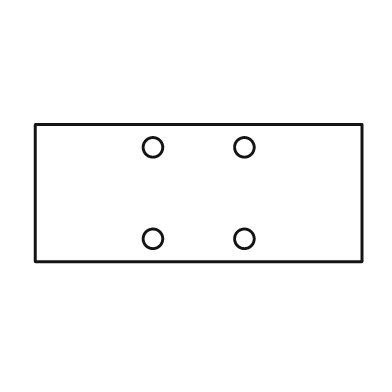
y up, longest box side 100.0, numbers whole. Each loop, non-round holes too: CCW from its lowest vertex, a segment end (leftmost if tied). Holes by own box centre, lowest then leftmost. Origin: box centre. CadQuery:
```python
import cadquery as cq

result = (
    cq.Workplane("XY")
    .moveTo(-50.0, -21.0)
    .lineTo(50.0, -21.0)
    .lineTo(50.0, 21.0)
    .lineTo(-50.0, 21.0)
    .close()
    .moveTo(-14.0, -14.0)
    .circle(3.0)
    .moveTo(14.0, -14.0)
    .circle(3.0)
    .moveTo(-14.0, 14.0)
    .circle(3.0)
    .moveTo(14.0, 14.0)
    .circle(3.0)
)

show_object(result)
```